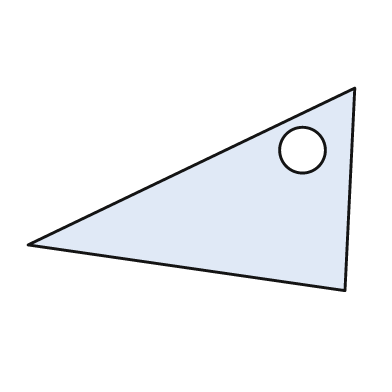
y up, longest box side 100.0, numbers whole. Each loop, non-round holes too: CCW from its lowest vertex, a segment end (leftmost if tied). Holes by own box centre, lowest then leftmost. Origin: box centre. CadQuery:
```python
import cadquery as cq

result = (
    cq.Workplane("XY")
    .moveTo(47.0, -31.0)
    .lineTo(50.0, 31.0)
    .lineTo(-50.0, -17.0)
    .close()
    .moveTo(34.0, 12.0)
    .circle(7.0)
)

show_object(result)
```